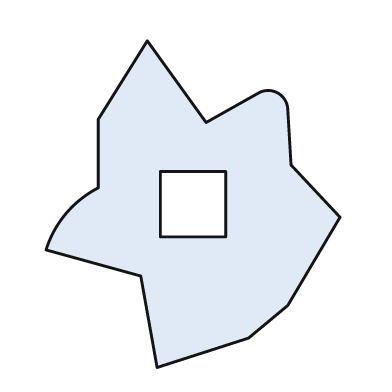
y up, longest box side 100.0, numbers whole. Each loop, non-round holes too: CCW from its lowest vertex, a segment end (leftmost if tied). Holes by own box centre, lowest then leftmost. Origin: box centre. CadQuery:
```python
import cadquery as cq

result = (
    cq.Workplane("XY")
    .moveTo(-11.0, -50.0)
    .lineTo(17.0, -41.0)
    .lineTo(29.0, -31.0)
    .lineTo(45.0, -4.0)
    .lineTo(30.0, 12.0)
    .lineTo(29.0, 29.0)
    .threePointArc((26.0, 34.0), (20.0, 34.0))
    .lineTo(4.0, 25.0)
    .lineTo(-14.0, 50.0)
    .lineTo(-29.0, 26.0)
    .lineTo(-29.0, 5.0)
    .threePointArc((-39.0, -3.0), (-45.0, -14.0))
    .lineTo(-16.0, -22.0)
    .close()
    .moveTo(-10.0, -10.0)
    .lineTo(10.0, -10.0)
    .lineTo(10.0, 10.0)
    .lineTo(-10.0, 10.0)
    .close()
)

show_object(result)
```